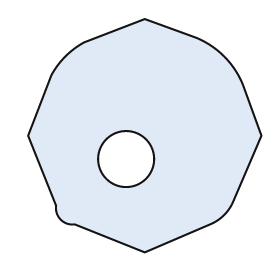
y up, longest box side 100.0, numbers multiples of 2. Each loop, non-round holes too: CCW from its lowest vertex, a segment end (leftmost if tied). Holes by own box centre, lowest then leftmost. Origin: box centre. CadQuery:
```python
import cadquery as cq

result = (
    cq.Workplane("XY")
    .moveTo(0.0, -50.0)
    .lineTo(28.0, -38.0)
    .threePointArc((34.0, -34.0), (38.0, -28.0))
    .lineTo(50.0, 0.0)
    .lineTo(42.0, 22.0)
    .threePointArc((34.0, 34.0), (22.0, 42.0))
    .lineTo(0.0, 50.0)
    .lineTo(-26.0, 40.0)
    .threePointArc((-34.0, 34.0), (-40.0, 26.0))
    .lineTo(-50.0, 0.0)
    .lineTo(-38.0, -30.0)
    .threePointArc((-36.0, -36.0), (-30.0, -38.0))
    .close()
    .moveTo(-8.0, -10.0)
    .circle(12.0)
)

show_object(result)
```